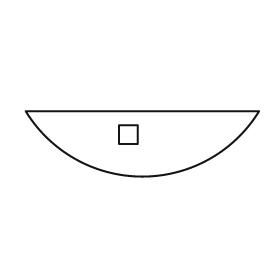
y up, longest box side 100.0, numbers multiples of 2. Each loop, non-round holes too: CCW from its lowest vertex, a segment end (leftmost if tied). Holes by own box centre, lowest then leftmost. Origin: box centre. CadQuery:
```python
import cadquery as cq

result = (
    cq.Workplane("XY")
    .moveTo(-50.0, 14.0)
    .threePointArc((0.0, -14.0), (50.0, 14.0))
    .close()
    .moveTo(-10.0, 0.0)
    .lineTo(-2.0, 0.0)
    .lineTo(-2.0, 8.0)
    .lineTo(-10.0, 8.0)
    .close()
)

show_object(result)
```